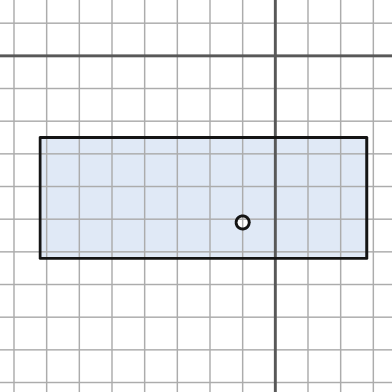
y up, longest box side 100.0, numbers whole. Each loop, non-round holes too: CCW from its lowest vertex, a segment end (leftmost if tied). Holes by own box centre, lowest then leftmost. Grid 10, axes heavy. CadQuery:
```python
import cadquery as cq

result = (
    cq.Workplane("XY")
    .moveTo(-72.0, -62.0)
    .lineTo(28.0, -62.0)
    .lineTo(28.0, -25.0)
    .lineTo(-72.0, -25.0)
    .close()
    .moveTo(-10.0, -51.0)
    .circle(2.0)
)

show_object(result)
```